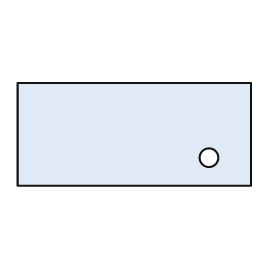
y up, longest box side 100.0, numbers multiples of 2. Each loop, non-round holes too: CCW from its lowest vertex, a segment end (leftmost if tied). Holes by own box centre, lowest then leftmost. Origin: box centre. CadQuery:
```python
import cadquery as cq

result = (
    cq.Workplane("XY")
    .moveTo(-50.0, -22.0)
    .lineTo(50.0, -22.0)
    .lineTo(50.0, 22.0)
    .lineTo(-50.0, 22.0)
    .close()
    .moveTo(32.0, -10.0)
    .circle(4.0)
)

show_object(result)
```